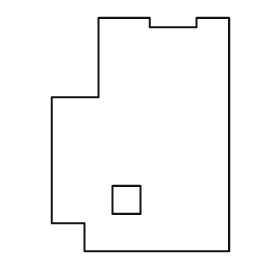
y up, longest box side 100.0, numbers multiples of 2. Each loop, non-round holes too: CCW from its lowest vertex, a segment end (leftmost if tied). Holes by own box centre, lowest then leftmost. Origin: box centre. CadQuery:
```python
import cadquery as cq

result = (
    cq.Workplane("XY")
    .moveTo(-24.0, -50.0)
    .lineTo(38.0, -50.0)
    .lineTo(38.0, 50.0)
    .lineTo(24.0, 50.0)
    .lineTo(24.0, 46.0)
    .lineTo(4.0, 46.0)
    .lineTo(4.0, 50.0)
    .lineTo(-18.0, 50.0)
    .lineTo(-18.0, 16.0)
    .lineTo(-38.0, 16.0)
    .lineTo(-38.0, -38.0)
    .lineTo(-24.0, -38.0)
    .close()
    .moveTo(-12.0, -34.0)
    .lineTo(0.0, -34.0)
    .lineTo(0.0, -22.0)
    .lineTo(-12.0, -22.0)
    .close()
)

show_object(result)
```